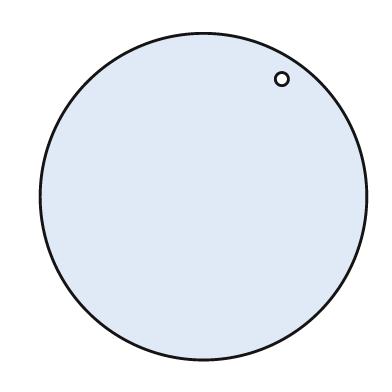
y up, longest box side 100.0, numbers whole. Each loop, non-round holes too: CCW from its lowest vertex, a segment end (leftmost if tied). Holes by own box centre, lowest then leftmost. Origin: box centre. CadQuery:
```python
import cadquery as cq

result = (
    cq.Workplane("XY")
    .moveTo(0.0, 0.0)
    .circle(50.0)
    .moveTo(24.0, 36.0)
    .circle(2.0)
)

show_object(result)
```